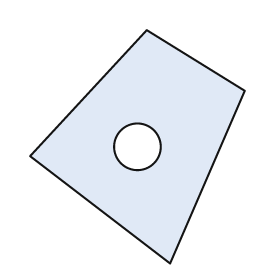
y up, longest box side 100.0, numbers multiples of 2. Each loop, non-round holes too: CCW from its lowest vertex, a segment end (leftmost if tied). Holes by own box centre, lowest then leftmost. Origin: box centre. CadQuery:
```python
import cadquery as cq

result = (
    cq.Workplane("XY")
    .moveTo(14.0, -50.0)
    .lineTo(46.0, 24.0)
    .lineTo(4.0, 50.0)
    .lineTo(-46.0, -4.0)
    .close()
    .moveTo(0.0, 0.0)
    .circle(10.0)
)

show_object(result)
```